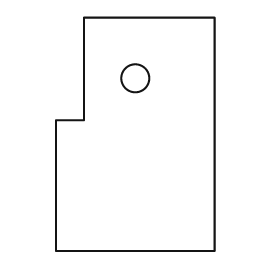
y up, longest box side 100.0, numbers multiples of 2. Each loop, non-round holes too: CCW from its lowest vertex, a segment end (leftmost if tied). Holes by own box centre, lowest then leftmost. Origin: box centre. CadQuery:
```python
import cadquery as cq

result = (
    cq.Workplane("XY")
    .moveTo(-34.0, -50.0)
    .lineTo(34.0, -50.0)
    .lineTo(34.0, 50.0)
    .lineTo(-22.0, 50.0)
    .lineTo(-22.0, 6.0)
    .lineTo(-34.0, 6.0)
    .close()
    .moveTo(0.0, 24.0)
    .circle(6.0)
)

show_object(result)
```